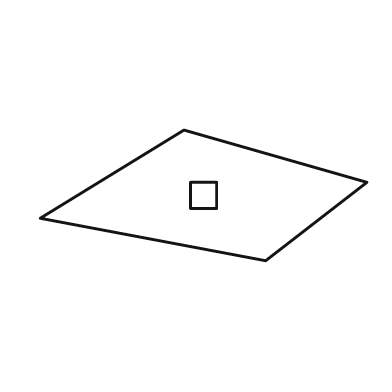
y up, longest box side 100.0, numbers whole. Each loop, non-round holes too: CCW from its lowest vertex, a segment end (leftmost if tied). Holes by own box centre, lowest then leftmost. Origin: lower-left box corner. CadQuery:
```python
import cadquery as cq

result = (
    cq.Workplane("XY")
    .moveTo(69.0, 0.0)
    .lineTo(100.0, 24.0)
    .lineTo(44.0, 40.0)
    .lineTo(0.0, 13.0)
    .close()
    .moveTo(46.0, 16.0)
    .lineTo(54.0, 16.0)
    .lineTo(54.0, 24.0)
    .lineTo(46.0, 24.0)
    .close()
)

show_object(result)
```